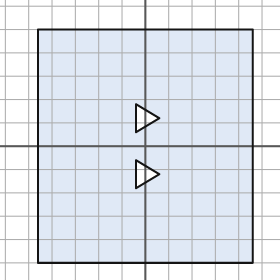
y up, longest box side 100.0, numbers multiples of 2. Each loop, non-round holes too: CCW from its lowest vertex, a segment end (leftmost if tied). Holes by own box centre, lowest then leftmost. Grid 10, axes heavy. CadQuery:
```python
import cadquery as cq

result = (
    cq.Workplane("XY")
    .moveTo(-46.0, -50.0)
    .lineTo(46.0, -50.0)
    .lineTo(46.0, 50.0)
    .lineTo(-46.0, 50.0)
    .close()
    .moveTo(-4.0, -18.0)
    .lineTo(6.0, -12.0)
    .lineTo(-4.0, -6.0)
    .close()
    .moveTo(-4.0, 6.0)
    .lineTo(6.0, 12.0)
    .lineTo(-4.0, 18.0)
    .close()
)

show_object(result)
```